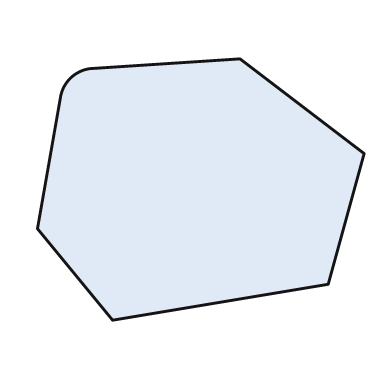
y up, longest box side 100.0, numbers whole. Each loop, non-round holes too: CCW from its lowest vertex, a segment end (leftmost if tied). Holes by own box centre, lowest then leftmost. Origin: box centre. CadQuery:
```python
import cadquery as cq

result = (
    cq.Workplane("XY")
    .moveTo(-27.0, -40.0)
    .lineTo(39.0, -29.0)
    .lineTo(50.0, 11.0)
    .lineTo(12.0, 40.0)
    .lineTo(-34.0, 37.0)
    .threePointArc((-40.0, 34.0), (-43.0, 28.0))
    .lineTo(-50.0, -12.0)
    .close()
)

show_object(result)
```